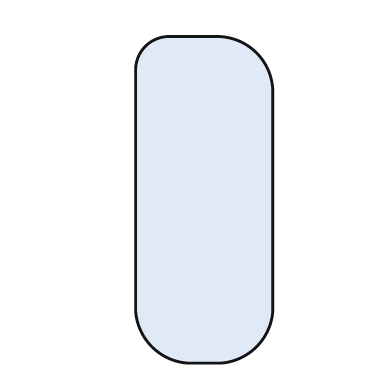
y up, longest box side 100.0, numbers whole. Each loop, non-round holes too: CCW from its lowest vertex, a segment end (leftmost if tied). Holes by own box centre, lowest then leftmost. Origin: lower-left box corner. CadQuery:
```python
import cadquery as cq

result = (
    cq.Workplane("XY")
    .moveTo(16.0, 0.0)
    .lineTo(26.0, 0.0)
    .threePointArc((37.0, 5.0), (42.0, 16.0))
    .lineTo(42.0, 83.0)
    .threePointArc((37.0, 95.0), (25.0, 100.0))
    .lineTo(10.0, 100.0)
    .threePointArc((3.0, 97.0), (0.0, 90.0))
    .lineTo(0.0, 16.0)
    .threePointArc((5.0, 5.0), (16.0, 0.0))
    .close()
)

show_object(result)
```